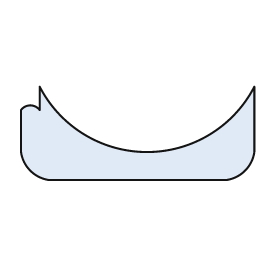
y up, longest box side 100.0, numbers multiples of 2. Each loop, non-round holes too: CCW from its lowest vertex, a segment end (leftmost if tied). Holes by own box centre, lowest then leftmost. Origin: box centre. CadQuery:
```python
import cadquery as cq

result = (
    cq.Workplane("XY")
    .moveTo(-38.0, -20.0)
    .lineTo(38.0, -20.0)
    .threePointArc((46.0, -16.0), (50.0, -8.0))
    .lineTo(50.0, 20.0)
    .threePointArc((4.0, -8.0), (-42.0, 20.0))
    .lineTo(-42.0, 10.0)
    .threePointArc((-46.0, 12.0), (-50.0, 10.0))
    .lineTo(-50.0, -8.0)
    .threePointArc((-46.0, -16.0), (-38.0, -20.0))
    .close()
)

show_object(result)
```